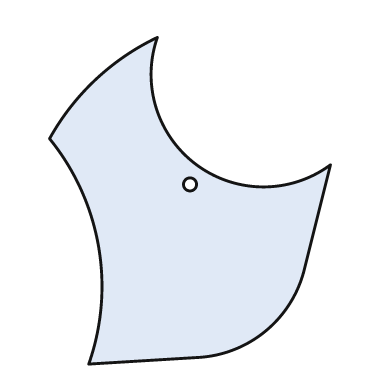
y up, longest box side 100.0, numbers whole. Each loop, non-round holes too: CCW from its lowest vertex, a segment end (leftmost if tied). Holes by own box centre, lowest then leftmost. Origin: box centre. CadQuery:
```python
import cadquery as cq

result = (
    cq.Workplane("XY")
    .moveTo(-31.0, -50.0)
    .lineTo(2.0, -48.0)
    .threePointArc((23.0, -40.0), (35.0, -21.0))
    .lineTo(43.0, 11.0)
    .threePointArc((2.0, 11.0), (-10.0, 50.0))
    .threePointArc((-29.0, 37.0), (-43.0, 19.0))
    .threePointArc((-28.0, -14.0), (-31.0, -50.0))
    .close()
    .moveTo(0.0, 5.0)
    .circle(2.0)
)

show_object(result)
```